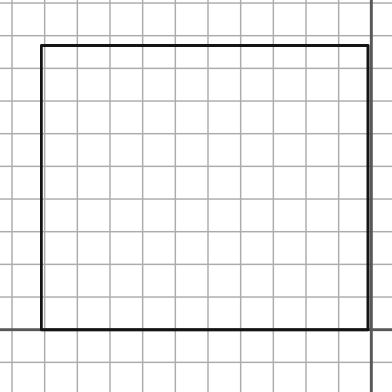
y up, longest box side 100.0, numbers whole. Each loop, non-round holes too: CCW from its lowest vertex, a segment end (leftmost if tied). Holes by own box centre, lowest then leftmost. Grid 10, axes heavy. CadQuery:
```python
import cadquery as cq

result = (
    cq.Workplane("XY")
    .moveTo(-101.0, 0.0)
    .lineTo(-1.0, 0.0)
    .lineTo(-1.0, 87.0)
    .lineTo(-101.0, 87.0)
    .close()
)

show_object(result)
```